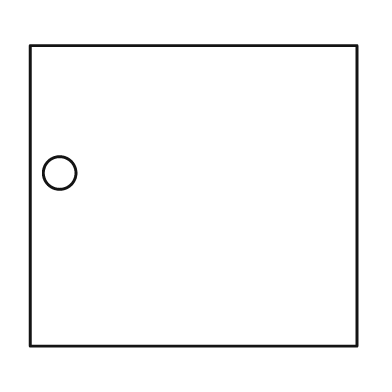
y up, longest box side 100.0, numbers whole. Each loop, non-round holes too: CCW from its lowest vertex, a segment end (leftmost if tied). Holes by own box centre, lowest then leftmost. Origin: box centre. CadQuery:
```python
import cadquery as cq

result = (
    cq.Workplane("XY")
    .moveTo(-50.0, -46.0)
    .lineTo(50.0, -46.0)
    .lineTo(50.0, 46.0)
    .lineTo(-50.0, 46.0)
    .close()
    .moveTo(-41.0, 7.0)
    .circle(5.0)
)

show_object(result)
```